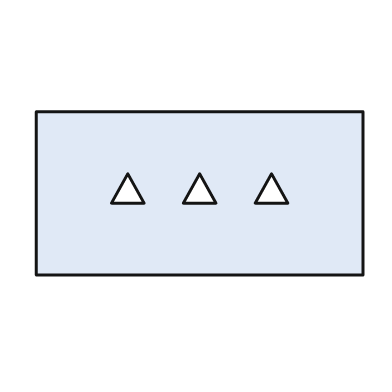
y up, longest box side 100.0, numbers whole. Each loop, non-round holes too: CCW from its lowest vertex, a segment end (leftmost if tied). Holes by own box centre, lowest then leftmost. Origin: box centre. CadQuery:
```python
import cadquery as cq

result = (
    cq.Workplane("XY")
    .moveTo(-50.0, -25.0)
    .lineTo(50.0, -25.0)
    .lineTo(50.0, 25.0)
    .lineTo(-50.0, 25.0)
    .close()
    .moveTo(-27.0, -3.0)
    .lineTo(-17.0, -3.0)
    .lineTo(-22.0, 6.0)
    .close()
    .moveTo(-5.0, -3.0)
    .lineTo(5.0, -3.0)
    .lineTo(0.0, 6.0)
    .close()
    .moveTo(17.0, -3.0)
    .lineTo(27.0, -3.0)
    .lineTo(22.0, 6.0)
    .close()
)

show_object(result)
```